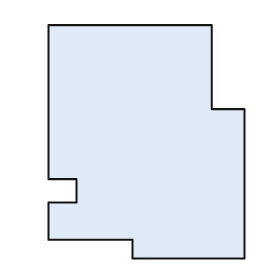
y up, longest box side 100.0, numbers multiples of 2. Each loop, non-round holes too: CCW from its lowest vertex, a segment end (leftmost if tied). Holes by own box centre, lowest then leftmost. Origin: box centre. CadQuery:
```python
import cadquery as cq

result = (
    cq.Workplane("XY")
    .moveTo(-6.0, -50.0)
    .lineTo(42.0, -50.0)
    .lineTo(42.0, 14.0)
    .lineTo(28.0, 14.0)
    .lineTo(28.0, 50.0)
    .lineTo(-42.0, 50.0)
    .lineTo(-42.0, -16.0)
    .lineTo(-30.0, -16.0)
    .lineTo(-30.0, -26.0)
    .lineTo(-42.0, -26.0)
    .lineTo(-42.0, -42.0)
    .lineTo(-6.0, -42.0)
    .close()
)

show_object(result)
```